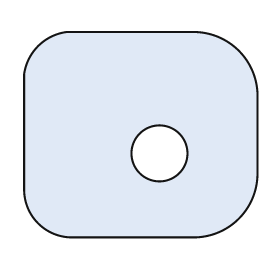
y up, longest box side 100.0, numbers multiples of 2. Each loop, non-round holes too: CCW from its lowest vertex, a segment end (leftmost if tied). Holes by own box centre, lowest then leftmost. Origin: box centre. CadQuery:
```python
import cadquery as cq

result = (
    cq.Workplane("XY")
    .moveTo(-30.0, -44.0)
    .lineTo(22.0, -44.0)
    .threePointArc((42.0, -36.0), (50.0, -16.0))
    .lineTo(50.0, 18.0)
    .threePointArc((42.0, 36.0), (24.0, 44.0))
    .lineTo(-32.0, 44.0)
    .threePointArc((-44.0, 38.0), (-50.0, 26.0))
    .lineTo(-50.0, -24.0)
    .threePointArc((-44.0, -38.0), (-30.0, -44.0))
    .close()
    .moveTo(8.0, -8.0)
    .circle(12.0)
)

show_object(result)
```